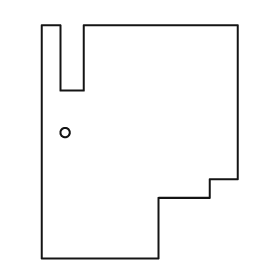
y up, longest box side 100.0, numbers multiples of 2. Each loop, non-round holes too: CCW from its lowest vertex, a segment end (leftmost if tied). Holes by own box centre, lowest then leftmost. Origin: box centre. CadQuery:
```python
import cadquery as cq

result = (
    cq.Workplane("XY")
    .moveTo(-42.0, -50.0)
    .lineTo(8.0, -50.0)
    .lineTo(8.0, -24.0)
    .lineTo(30.0, -24.0)
    .lineTo(30.0, -16.0)
    .lineTo(42.0, -16.0)
    .lineTo(42.0, 50.0)
    .lineTo(-24.0, 50.0)
    .lineTo(-24.0, 22.0)
    .lineTo(-34.0, 22.0)
    .lineTo(-34.0, 50.0)
    .lineTo(-42.0, 50.0)
    .close()
    .moveTo(-32.0, 4.0)
    .circle(2.0)
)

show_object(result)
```